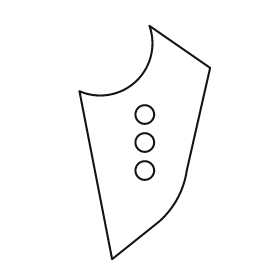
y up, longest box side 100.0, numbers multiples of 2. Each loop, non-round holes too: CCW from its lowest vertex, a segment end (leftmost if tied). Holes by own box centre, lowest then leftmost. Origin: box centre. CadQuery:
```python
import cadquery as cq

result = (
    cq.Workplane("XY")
    .moveTo(-14.0, -50.0)
    .lineTo(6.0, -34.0)
    .threePointArc((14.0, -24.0), (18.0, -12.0))
    .lineTo(28.0, 32.0)
    .lineTo(2.0, 50.0)
    .threePointArc((-4.0, 26.0), (-28.0, 22.0))
    .close()
    .moveTo(0.0, -12.0)
    .circle(4.0)
    .moveTo(0.0, 0.0)
    .circle(4.0)
    .moveTo(0.0, 12.0)
    .circle(4.0)
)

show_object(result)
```